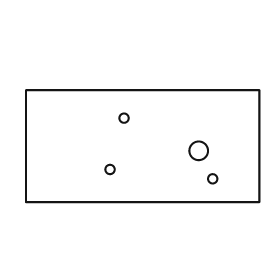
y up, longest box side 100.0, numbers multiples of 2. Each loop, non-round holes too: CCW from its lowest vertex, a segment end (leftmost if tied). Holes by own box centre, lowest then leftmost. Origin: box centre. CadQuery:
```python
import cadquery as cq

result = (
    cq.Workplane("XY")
    .moveTo(-50.0, -24.0)
    .lineTo(50.0, -24.0)
    .lineTo(50.0, 24.0)
    .lineTo(-50.0, 24.0)
    .close()
    .moveTo(30.0, -14.0)
    .circle(2.0)
    .moveTo(-14.0, -10.0)
    .circle(2.0)
    .moveTo(24.0, -2.0)
    .circle(4.0)
    .moveTo(-8.0, 12.0)
    .circle(2.0)
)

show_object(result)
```